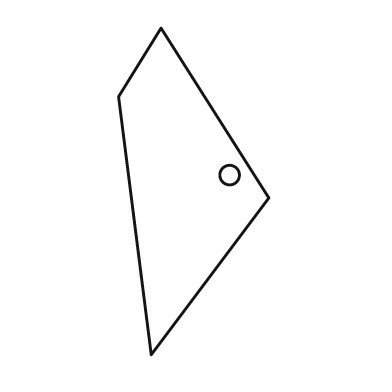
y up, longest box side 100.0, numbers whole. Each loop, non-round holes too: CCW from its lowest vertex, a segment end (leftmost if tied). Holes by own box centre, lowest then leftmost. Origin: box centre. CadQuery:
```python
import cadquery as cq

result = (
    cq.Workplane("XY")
    .moveTo(-13.0, -50.0)
    .lineTo(23.0, -2.0)
    .lineTo(-10.0, 50.0)
    .lineTo(-23.0, 29.0)
    .close()
    .moveTo(11.0, 5.0)
    .circle(3.0)
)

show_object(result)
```